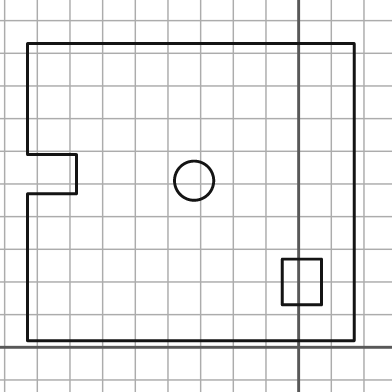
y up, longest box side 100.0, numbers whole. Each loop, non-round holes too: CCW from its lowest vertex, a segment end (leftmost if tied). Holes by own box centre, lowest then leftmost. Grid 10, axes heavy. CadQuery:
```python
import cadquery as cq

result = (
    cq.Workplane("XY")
    .moveTo(-83.0, 2.0)
    .lineTo(17.0, 2.0)
    .lineTo(17.0, 93.0)
    .lineTo(-83.0, 93.0)
    .lineTo(-83.0, 59.0)
    .lineTo(-68.0, 59.0)
    .lineTo(-68.0, 47.0)
    .lineTo(-83.0, 47.0)
    .close()
    .moveTo(-5.0, 13.0)
    .lineTo(7.0, 13.0)
    .lineTo(7.0, 27.0)
    .lineTo(-5.0, 27.0)
    .close()
    .moveTo(-32.0, 51.0)
    .circle(6.0)
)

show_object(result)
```